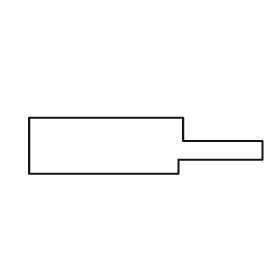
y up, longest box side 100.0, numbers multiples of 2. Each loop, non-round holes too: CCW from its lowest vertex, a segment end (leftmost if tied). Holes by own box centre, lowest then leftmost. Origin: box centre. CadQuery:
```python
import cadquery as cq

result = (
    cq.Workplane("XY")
    .moveTo(-50.0, -12.0)
    .lineTo(14.0, -12.0)
    .lineTo(14.0, -6.0)
    .lineTo(50.0, -6.0)
    .lineTo(50.0, 2.0)
    .lineTo(16.0, 2.0)
    .lineTo(16.0, 12.0)
    .lineTo(-50.0, 12.0)
    .close()
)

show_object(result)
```